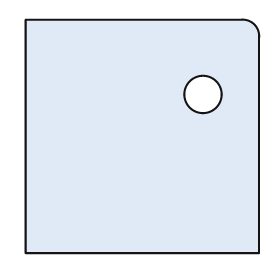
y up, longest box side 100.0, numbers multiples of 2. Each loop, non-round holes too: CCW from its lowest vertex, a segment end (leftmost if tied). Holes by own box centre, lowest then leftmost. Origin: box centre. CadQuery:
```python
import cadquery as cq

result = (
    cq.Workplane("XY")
    .moveTo(-50.0, -50.0)
    .lineTo(50.0, -50.0)
    .lineTo(50.0, 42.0)
    .threePointArc((48.0, 48.0), (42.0, 50.0))
    .lineTo(-50.0, 50.0)
    .close()
    .moveTo(26.0, 18.0)
    .circle(8.0)
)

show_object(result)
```